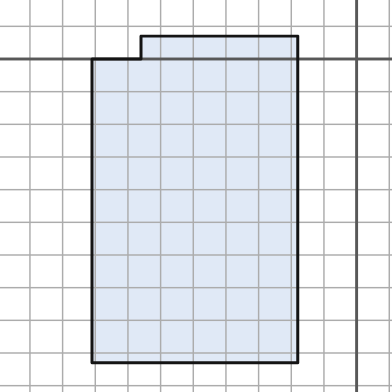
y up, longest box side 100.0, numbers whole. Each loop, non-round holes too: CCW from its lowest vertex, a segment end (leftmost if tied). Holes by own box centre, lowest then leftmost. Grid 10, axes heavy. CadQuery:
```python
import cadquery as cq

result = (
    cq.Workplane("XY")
    .moveTo(-81.0, -93.0)
    .lineTo(-18.0, -93.0)
    .lineTo(-18.0, 7.0)
    .lineTo(-66.0, 7.0)
    .lineTo(-66.0, 0.0)
    .lineTo(-81.0, 0.0)
    .close()
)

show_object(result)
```